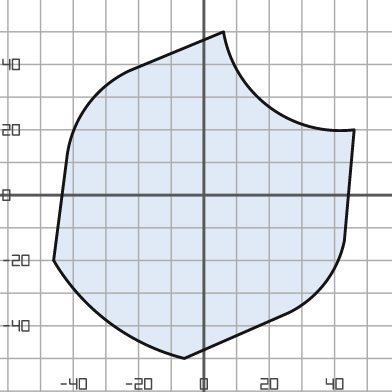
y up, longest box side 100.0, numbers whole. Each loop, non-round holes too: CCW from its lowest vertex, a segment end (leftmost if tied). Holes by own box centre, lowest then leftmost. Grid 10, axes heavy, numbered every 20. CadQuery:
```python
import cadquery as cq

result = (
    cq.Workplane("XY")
    .moveTo(-6.0, -50.0)
    .lineTo(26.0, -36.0)
    .threePointArc((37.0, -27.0), (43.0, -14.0))
    .lineTo(46.0, 20.0)
    .threePointArc((20.0, 27.0), (6.0, 50.0))
    .lineTo(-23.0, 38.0)
    .threePointArc((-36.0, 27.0), (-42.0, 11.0))
    .lineTo(-46.0, -20.0)
    .threePointArc((-29.0, -39.0), (-6.0, -50.0))
    .close()
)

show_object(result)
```